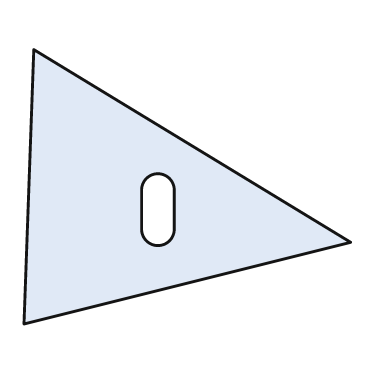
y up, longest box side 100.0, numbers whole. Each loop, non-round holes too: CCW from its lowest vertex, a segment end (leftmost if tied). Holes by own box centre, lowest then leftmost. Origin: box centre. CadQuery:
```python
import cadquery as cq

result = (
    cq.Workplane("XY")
    .moveTo(-50.0, -42.0)
    .lineTo(50.0, -17.0)
    .lineTo(-47.0, 42.0)
    .close()
    .moveTo(-14.0, -13.0)
    .threePointArc((-9.0, -18.0), (-4.0, -13.0))
    .lineTo(-4.0, -1.0)
    .threePointArc((-9.0, 4.0), (-14.0, -1.0))
    .close()
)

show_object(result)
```